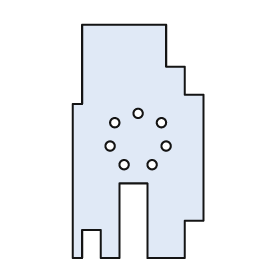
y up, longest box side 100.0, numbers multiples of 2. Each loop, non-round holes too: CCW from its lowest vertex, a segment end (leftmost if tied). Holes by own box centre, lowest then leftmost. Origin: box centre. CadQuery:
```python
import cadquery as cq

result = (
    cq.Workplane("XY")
    .moveTo(-28.0, -50.0)
    .lineTo(-24.0, -50.0)
    .lineTo(-24.0, -38.0)
    .lineTo(-16.0, -38.0)
    .lineTo(-16.0, -50.0)
    .lineTo(-8.0, -50.0)
    .lineTo(-8.0, -18.0)
    .lineTo(4.0, -18.0)
    .lineTo(4.0, -50.0)
    .lineTo(20.0, -50.0)
    .lineTo(20.0, -34.0)
    .lineTo(28.0, -34.0)
    .lineTo(28.0, 20.0)
    .lineTo(20.0, 20.0)
    .lineTo(20.0, 32.0)
    .lineTo(12.0, 32.0)
    .lineTo(12.0, 50.0)
    .lineTo(-24.0, 50.0)
    .lineTo(-24.0, 16.0)
    .lineTo(-28.0, 16.0)
    .close()
    .moveTo(-6.0, -10.0)
    .circle(2.0)
    .moveTo(6.0, -10.0)
    .circle(2.0)
    .moveTo(-12.0, -2.0)
    .circle(2.0)
    .moveTo(12.0, -2.0)
    .circle(2.0)
    .moveTo(-10.0, 8.0)
    .circle(2.0)
    .moveTo(10.0, 8.0)
    .circle(2.0)
    .moveTo(0.0, 12.0)
    .circle(2.0)
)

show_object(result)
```